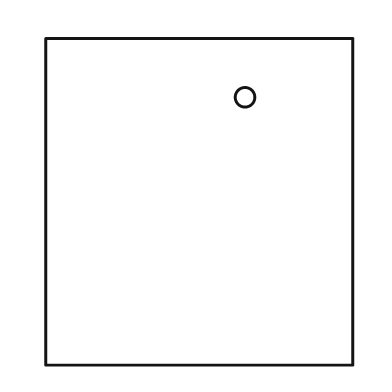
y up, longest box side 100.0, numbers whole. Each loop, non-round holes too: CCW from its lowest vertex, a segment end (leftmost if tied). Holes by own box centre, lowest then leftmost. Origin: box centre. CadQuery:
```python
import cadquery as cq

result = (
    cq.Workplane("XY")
    .moveTo(-47.0, -50.0)
    .lineTo(47.0, -50.0)
    .lineTo(47.0, 50.0)
    .lineTo(-47.0, 50.0)
    .close()
    .moveTo(14.0, 32.0)
    .circle(3.0)
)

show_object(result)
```